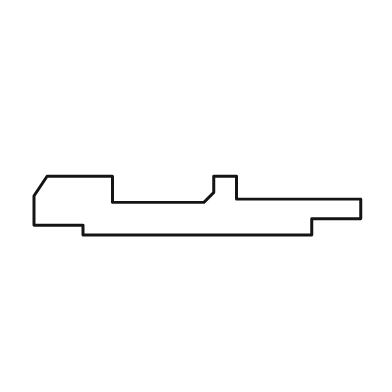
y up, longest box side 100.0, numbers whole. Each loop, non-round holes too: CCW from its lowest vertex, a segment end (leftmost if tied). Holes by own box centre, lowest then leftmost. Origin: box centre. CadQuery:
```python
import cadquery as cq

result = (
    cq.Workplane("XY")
    .moveTo(-35.0, -9.0)
    .lineTo(35.0, -9.0)
    .lineTo(35.0, -4.0)
    .lineTo(50.0, -4.0)
    .lineTo(50.0, 2.0)
    .lineTo(12.0, 2.0)
    .lineTo(12.0, 9.0)
    .lineTo(5.0, 9.0)
    .lineTo(5.0, 4.0)
    .lineTo(2.0, 1.0)
    .lineTo(-26.0, 1.0)
    .lineTo(-26.0, 9.0)
    .lineTo(-46.0, 9.0)
    .lineTo(-50.0, 3.0)
    .lineTo(-50.0, -6.0)
    .lineTo(-35.0, -6.0)
    .close()
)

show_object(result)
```